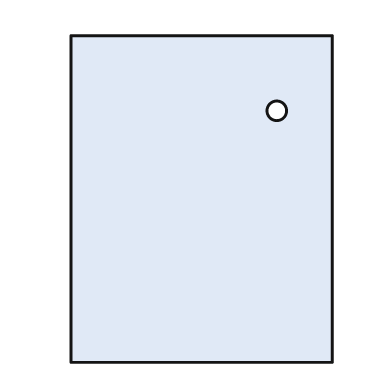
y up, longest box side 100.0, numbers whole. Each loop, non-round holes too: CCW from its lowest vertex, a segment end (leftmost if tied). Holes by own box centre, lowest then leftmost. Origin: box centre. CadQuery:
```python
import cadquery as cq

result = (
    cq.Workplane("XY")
    .moveTo(-40.0, -50.0)
    .lineTo(40.0, -50.0)
    .lineTo(40.0, 50.0)
    .lineTo(-40.0, 50.0)
    .close()
    .moveTo(23.0, 27.0)
    .circle(3.0)
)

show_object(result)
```